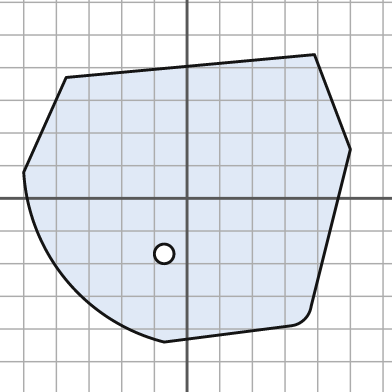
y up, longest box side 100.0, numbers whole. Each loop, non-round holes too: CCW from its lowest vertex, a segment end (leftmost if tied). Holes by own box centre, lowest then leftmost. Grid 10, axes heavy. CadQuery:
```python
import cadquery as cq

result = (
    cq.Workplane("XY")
    .moveTo(-7.0, -44.0)
    .lineTo(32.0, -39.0)
    .threePointArc((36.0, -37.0), (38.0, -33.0))
    .lineTo(50.0, 15.0)
    .lineTo(39.0, 44.0)
    .lineTo(-37.0, 37.0)
    .lineTo(-50.0, 8.0)
    .threePointArc((-37.0, -25.0), (-7.0, -44.0))
    .close()
    .moveTo(-7.0, -17.0)
    .circle(3.0)
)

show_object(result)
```